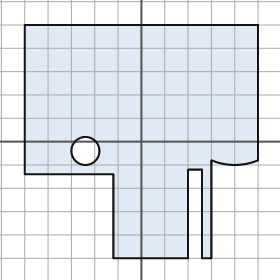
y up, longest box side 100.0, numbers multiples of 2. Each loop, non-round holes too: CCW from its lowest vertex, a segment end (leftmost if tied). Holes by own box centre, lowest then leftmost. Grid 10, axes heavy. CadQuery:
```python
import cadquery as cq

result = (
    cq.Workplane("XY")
    .moveTo(-12.0, -50.0)
    .lineTo(20.0, -50.0)
    .lineTo(20.0, -12.0)
    .lineTo(26.0, -12.0)
    .lineTo(26.0, -50.0)
    .lineTo(30.0, -50.0)
    .lineTo(30.0, -8.0)
    .threePointArc((40.0, -10.0), (50.0, -8.0))
    .lineTo(50.0, 50.0)
    .lineTo(-50.0, 50.0)
    .lineTo(-50.0, -14.0)
    .lineTo(-12.0, -14.0)
    .close()
    .moveTo(-24.0, -4.0)
    .circle(6.0)
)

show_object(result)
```